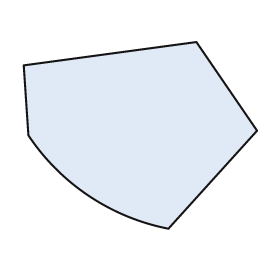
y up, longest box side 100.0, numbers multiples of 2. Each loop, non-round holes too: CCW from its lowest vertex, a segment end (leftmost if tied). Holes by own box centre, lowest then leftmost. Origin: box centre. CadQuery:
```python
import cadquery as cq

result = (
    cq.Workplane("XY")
    .moveTo(12.0, -40.0)
    .lineTo(50.0, 2.0)
    .lineTo(24.0, 40.0)
    .lineTo(-50.0, 30.0)
    .lineTo(-48.0, 0.0)
    .threePointArc((-22.0, -26.0), (12.0, -40.0))
    .close()
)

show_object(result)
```